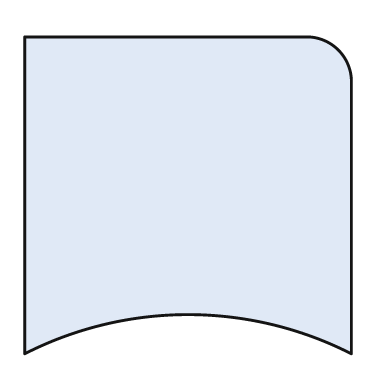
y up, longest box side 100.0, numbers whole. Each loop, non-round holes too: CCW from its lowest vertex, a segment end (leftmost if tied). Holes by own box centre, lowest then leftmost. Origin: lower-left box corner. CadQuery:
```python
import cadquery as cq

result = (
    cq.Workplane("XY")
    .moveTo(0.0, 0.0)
    .threePointArc((50.0, 12.0), (100.0, 0.0))
    .lineTo(100.0, 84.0)
    .threePointArc((96.0, 93.0), (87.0, 97.0))
    .lineTo(0.0, 97.0)
    .close()
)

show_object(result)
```